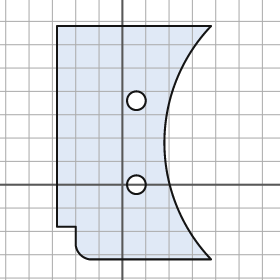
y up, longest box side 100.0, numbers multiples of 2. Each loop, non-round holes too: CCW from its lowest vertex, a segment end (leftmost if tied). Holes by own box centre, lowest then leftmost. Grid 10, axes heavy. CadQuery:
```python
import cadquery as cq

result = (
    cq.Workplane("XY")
    .moveTo(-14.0, -32.0)
    .lineTo(38.0, -32.0)
    .threePointArc((18.0, 18.0), (38.0, 68.0))
    .lineTo(-28.0, 68.0)
    .lineTo(-28.0, -18.0)
    .lineTo(-20.0, -18.0)
    .lineTo(-20.0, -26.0)
    .threePointArc((-18.0, -30.0), (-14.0, -32.0))
    .close()
    .moveTo(6.0, 0.0)
    .circle(4.0)
    .moveTo(6.0, 36.0)
    .circle(4.0)
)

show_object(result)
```